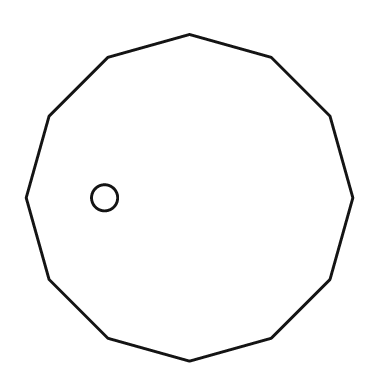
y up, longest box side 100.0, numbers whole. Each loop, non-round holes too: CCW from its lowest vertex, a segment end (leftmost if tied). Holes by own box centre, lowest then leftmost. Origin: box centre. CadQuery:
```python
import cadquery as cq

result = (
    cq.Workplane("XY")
    .moveTo(0.0, -50.0)
    .lineTo(25.0, -43.0)
    .lineTo(43.0, -25.0)
    .lineTo(50.0, 0.0)
    .lineTo(43.0, 25.0)
    .lineTo(25.0, 43.0)
    .lineTo(0.0, 50.0)
    .lineTo(-25.0, 43.0)
    .lineTo(-43.0, 25.0)
    .lineTo(-50.0, 0.0)
    .lineTo(-43.0, -25.0)
    .lineTo(-25.0, -43.0)
    .close()
    .moveTo(-26.0, 0.0)
    .circle(4.0)
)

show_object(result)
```